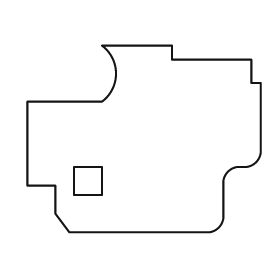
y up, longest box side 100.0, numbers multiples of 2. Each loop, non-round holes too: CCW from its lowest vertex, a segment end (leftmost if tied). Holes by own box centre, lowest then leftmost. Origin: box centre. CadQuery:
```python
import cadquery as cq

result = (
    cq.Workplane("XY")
    .moveTo(-32.0, -40.0)
    .lineTo(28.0, -40.0)
    .threePointArc((32.0, -38.0), (34.0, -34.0))
    .lineTo(34.0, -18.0)
    .threePointArc((36.0, -14.0), (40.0, -12.0))
    .lineTo(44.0, -12.0)
    .threePointArc((48.0, -10.0), (50.0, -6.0))
    .lineTo(50.0, 24.0)
    .lineTo(46.0, 24.0)
    .lineTo(46.0, 34.0)
    .lineTo(12.0, 34.0)
    .lineTo(12.0, 40.0)
    .lineTo(-18.0, 40.0)
    .threePointArc((-12.0, 28.0), (-18.0, 16.0))
    .lineTo(-50.0, 16.0)
    .lineTo(-50.0, -20.0)
    .lineTo(-38.0, -20.0)
    .lineTo(-38.0, -32.0)
    .close()
    .moveTo(-30.0, -24.0)
    .lineTo(-18.0, -24.0)
    .lineTo(-18.0, -12.0)
    .lineTo(-30.0, -12.0)
    .close()
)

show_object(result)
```